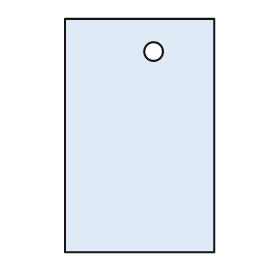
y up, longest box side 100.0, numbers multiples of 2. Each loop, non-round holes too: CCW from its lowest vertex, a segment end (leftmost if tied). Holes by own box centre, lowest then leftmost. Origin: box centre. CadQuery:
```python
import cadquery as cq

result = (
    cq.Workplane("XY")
    .moveTo(-32.0, -50.0)
    .lineTo(32.0, -50.0)
    .lineTo(32.0, 50.0)
    .lineTo(-32.0, 50.0)
    .close()
    .moveTo(6.0, 36.0)
    .circle(4.0)
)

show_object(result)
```